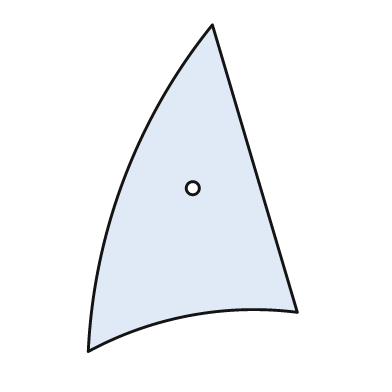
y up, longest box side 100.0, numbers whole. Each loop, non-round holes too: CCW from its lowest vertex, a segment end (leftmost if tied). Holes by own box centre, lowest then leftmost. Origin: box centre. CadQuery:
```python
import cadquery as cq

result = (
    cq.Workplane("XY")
    .moveTo(-32.0, -50.0)
    .threePointArc((-1.0, -39.0), (32.0, -38.0))
    .lineTo(6.0, 50.0)
    .threePointArc((-21.0, 3.0), (-32.0, -50.0))
    .close()
    .moveTo(0.0, 0.0)
    .circle(2.0)
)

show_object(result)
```